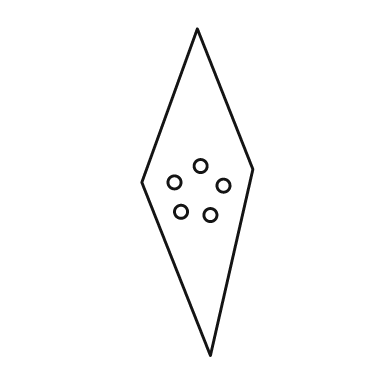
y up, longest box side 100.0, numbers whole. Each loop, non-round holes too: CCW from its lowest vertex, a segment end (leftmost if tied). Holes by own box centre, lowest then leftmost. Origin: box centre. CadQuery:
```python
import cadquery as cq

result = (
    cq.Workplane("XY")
    .moveTo(4.0, -50.0)
    .lineTo(17.0, 7.0)
    .lineTo(0.0, 50.0)
    .lineTo(-17.0, 3.0)
    .close()
    .moveTo(4.0, -7.0)
    .circle(2.0)
    .moveTo(-5.0, -6.0)
    .circle(2.0)
    .moveTo(8.0, 2.0)
    .circle(2.0)
    .moveTo(-7.0, 3.0)
    .circle(2.0)
    .moveTo(1.0, 8.0)
    .circle(2.0)
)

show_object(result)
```